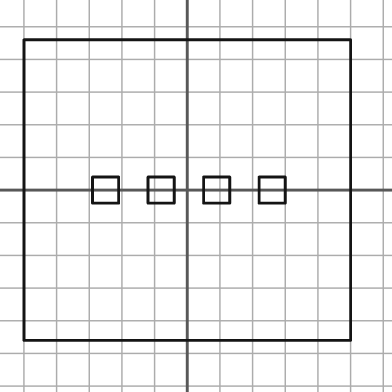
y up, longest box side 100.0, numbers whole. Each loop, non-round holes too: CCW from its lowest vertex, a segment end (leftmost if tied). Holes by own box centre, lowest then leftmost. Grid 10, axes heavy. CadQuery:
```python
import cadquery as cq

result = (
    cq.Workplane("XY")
    .moveTo(-50.0, -46.0)
    .lineTo(50.0, -46.0)
    .lineTo(50.0, 46.0)
    .lineTo(-50.0, 46.0)
    .close()
    .moveTo(-29.0, -4.0)
    .lineTo(-21.0, -4.0)
    .lineTo(-21.0, 4.0)
    .lineTo(-29.0, 4.0)
    .close()
    .moveTo(-12.0, -4.0)
    .lineTo(-4.0, -4.0)
    .lineTo(-4.0, 4.0)
    .lineTo(-12.0, 4.0)
    .close()
    .moveTo(5.0, -4.0)
    .lineTo(13.0, -4.0)
    .lineTo(13.0, 4.0)
    .lineTo(5.0, 4.0)
    .close()
    .moveTo(22.0, -4.0)
    .lineTo(30.0, -4.0)
    .lineTo(30.0, 4.0)
    .lineTo(22.0, 4.0)
    .close()
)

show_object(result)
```